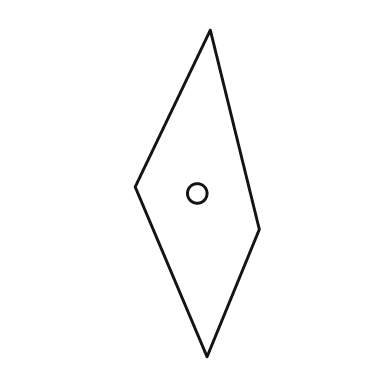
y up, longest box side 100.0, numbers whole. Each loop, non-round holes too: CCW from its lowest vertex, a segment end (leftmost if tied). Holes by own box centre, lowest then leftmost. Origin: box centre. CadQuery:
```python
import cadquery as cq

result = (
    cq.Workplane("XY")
    .moveTo(3.0, -50.0)
    .lineTo(19.0, -11.0)
    .lineTo(4.0, 50.0)
    .lineTo(-19.0, 2.0)
    .close()
    .moveTo(0.0, 0.0)
    .circle(3.0)
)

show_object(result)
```